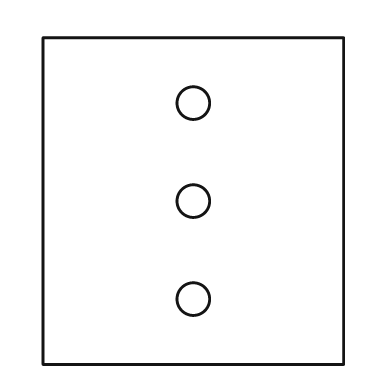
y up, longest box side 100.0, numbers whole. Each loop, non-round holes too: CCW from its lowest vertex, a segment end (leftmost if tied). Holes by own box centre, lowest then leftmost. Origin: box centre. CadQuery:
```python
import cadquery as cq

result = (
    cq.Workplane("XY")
    .moveTo(-46.0, -50.0)
    .lineTo(46.0, -50.0)
    .lineTo(46.0, 50.0)
    .lineTo(-46.0, 50.0)
    .close()
    .moveTo(0.0, -30.0)
    .circle(5.0)
    .moveTo(0.0, 0.0)
    .circle(5.0)
    .moveTo(0.0, 30.0)
    .circle(5.0)
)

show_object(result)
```